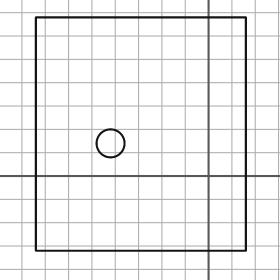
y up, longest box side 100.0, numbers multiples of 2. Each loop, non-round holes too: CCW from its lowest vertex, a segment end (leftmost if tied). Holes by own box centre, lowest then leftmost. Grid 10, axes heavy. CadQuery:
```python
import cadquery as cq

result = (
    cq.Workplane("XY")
    .moveTo(-74.0, -32.0)
    .lineTo(16.0, -32.0)
    .lineTo(16.0, 68.0)
    .lineTo(-74.0, 68.0)
    .close()
    .moveTo(-42.0, 14.0)
    .circle(6.0)
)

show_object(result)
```